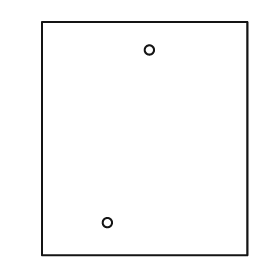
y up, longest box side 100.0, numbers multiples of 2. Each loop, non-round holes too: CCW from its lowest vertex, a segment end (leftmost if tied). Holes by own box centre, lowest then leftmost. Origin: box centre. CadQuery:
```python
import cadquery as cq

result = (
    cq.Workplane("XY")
    .moveTo(-44.0, -50.0)
    .lineTo(44.0, -50.0)
    .lineTo(44.0, 50.0)
    .lineTo(-44.0, 50.0)
    .close()
    .moveTo(-16.0, -36.0)
    .circle(2.0)
    .moveTo(2.0, 38.0)
    .circle(2.0)
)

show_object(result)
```